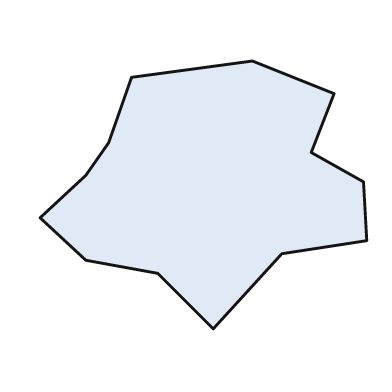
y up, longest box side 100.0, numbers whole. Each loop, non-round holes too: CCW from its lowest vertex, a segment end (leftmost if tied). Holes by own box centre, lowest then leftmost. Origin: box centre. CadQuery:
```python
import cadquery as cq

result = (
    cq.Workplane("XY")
    .moveTo(3.0, -41.0)
    .lineTo(24.0, -18.0)
    .lineTo(50.0, -14.0)
    .lineTo(49.0, 4.0)
    .lineTo(33.0, 13.0)
    .lineTo(40.0, 31.0)
    .lineTo(15.0, 41.0)
    .lineTo(-22.0, 36.0)
    .lineTo(-29.0, 16.0)
    .lineTo(-36.0, 6.0)
    .lineTo(-50.0, -7.0)
    .lineTo(-36.0, -20.0)
    .lineTo(-14.0, -24.0)
    .close()
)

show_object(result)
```